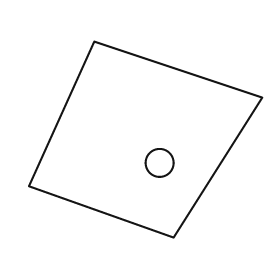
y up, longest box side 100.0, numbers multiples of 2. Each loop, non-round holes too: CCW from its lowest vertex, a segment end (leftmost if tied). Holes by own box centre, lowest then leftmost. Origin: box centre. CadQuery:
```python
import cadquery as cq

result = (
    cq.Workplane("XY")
    .moveTo(12.0, -42.0)
    .lineTo(50.0, 18.0)
    .lineTo(-22.0, 42.0)
    .lineTo(-50.0, -20.0)
    .close()
    .moveTo(6.0, -10.0)
    .circle(6.0)
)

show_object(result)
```